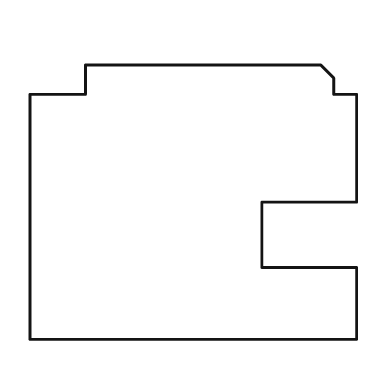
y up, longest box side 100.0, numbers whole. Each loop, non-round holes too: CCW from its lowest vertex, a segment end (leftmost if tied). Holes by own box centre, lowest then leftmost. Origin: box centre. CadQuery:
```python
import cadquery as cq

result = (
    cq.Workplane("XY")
    .moveTo(-50.0, -42.0)
    .lineTo(50.0, -42.0)
    .lineTo(50.0, -20.0)
    .lineTo(21.0, -20.0)
    .lineTo(21.0, 0.0)
    .lineTo(50.0, 0.0)
    .lineTo(50.0, 33.0)
    .lineTo(43.0, 33.0)
    .lineTo(43.0, 38.0)
    .lineTo(39.0, 42.0)
    .lineTo(-33.0, 42.0)
    .lineTo(-33.0, 33.0)
    .lineTo(-50.0, 33.0)
    .close()
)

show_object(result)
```